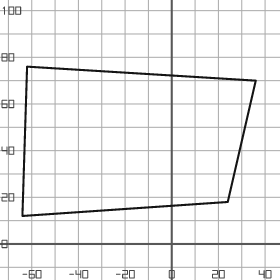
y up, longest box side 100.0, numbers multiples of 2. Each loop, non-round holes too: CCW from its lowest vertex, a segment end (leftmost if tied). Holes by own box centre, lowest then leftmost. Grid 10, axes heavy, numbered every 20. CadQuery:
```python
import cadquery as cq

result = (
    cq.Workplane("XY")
    .moveTo(-64.0, 12.0)
    .lineTo(24.0, 18.0)
    .lineTo(36.0, 70.0)
    .lineTo(-62.0, 76.0)
    .close()
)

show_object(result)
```